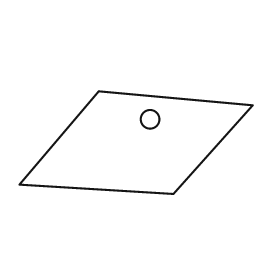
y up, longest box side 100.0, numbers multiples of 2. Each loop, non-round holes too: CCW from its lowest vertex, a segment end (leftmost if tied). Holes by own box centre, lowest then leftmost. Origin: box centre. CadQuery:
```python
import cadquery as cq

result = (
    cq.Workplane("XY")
    .moveTo(16.0, -22.0)
    .lineTo(50.0, 16.0)
    .lineTo(-16.0, 22.0)
    .lineTo(-50.0, -18.0)
    .close()
    .moveTo(6.0, 10.0)
    .circle(4.0)
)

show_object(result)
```